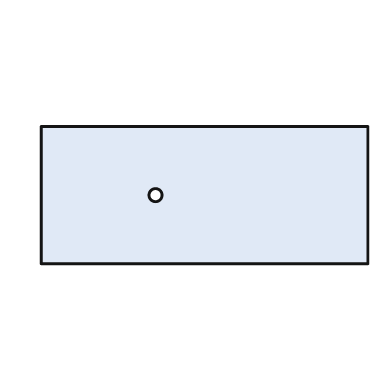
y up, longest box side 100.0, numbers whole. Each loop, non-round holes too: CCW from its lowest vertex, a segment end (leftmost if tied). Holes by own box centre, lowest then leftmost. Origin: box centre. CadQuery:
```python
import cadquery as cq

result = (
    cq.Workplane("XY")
    .moveTo(-50.0, -21.0)
    .lineTo(50.0, -21.0)
    .lineTo(50.0, 21.0)
    .lineTo(-50.0, 21.0)
    .close()
    .moveTo(-15.0, 0.0)
    .circle(2.0)
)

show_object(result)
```